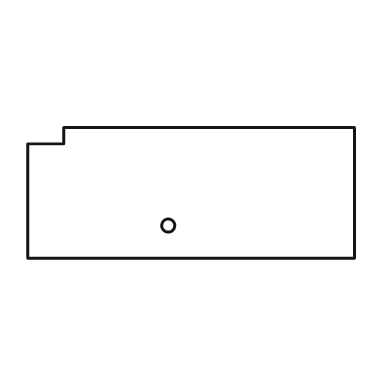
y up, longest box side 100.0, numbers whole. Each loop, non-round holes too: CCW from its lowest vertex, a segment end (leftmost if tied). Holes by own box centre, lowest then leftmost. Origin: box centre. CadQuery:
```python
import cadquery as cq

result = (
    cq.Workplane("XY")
    .moveTo(-50.0, -20.0)
    .lineTo(50.0, -20.0)
    .lineTo(50.0, 20.0)
    .lineTo(-39.0, 20.0)
    .lineTo(-39.0, 15.0)
    .lineTo(-50.0, 15.0)
    .close()
    .moveTo(-7.0, -10.0)
    .circle(2.0)
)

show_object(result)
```